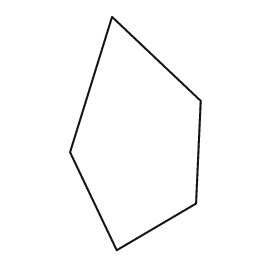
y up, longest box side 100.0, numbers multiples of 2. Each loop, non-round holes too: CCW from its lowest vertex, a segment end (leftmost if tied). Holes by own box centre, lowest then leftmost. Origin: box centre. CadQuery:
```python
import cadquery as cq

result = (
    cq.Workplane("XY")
    .moveTo(-8.0, -50.0)
    .lineTo(26.0, -30.0)
    .lineTo(28.0, 14.0)
    .lineTo(-10.0, 50.0)
    .lineTo(-28.0, -8.0)
    .close()
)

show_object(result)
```